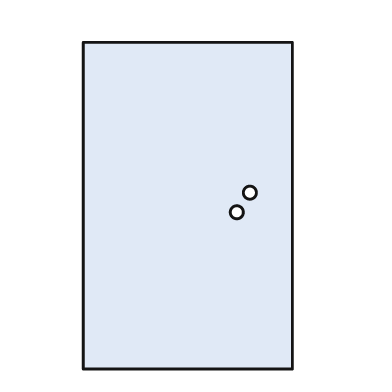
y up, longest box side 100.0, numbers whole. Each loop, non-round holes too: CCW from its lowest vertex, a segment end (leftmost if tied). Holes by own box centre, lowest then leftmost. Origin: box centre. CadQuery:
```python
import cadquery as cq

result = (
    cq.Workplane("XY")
    .moveTo(-32.0, -50.0)
    .lineTo(32.0, -50.0)
    .lineTo(32.0, 50.0)
    .lineTo(-32.0, 50.0)
    .close()
    .moveTo(15.0, -2.0)
    .circle(2.0)
    .moveTo(19.0, 4.0)
    .circle(2.0)
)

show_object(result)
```